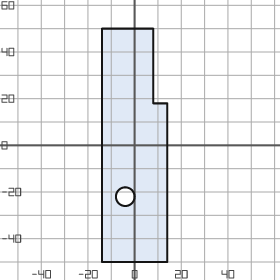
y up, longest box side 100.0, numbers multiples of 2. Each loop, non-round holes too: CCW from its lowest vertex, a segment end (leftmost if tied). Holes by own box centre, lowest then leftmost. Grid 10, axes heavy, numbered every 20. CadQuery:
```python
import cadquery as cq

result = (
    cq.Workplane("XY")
    .moveTo(-14.0, -50.0)
    .lineTo(14.0, -50.0)
    .lineTo(14.0, 18.0)
    .lineTo(8.0, 18.0)
    .lineTo(8.0, 50.0)
    .lineTo(-14.0, 50.0)
    .close()
    .moveTo(-4.0, -22.0)
    .circle(4.0)
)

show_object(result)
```